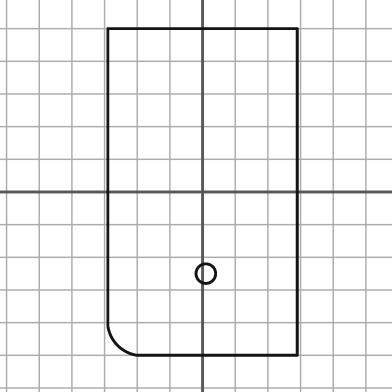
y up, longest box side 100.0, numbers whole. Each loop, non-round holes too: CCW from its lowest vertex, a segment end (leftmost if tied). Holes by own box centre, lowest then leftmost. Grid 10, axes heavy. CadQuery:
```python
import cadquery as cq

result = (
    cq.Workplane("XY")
    .moveTo(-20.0, -50.0)
    .lineTo(29.0, -50.0)
    .lineTo(29.0, 50.0)
    .lineTo(-29.0, 50.0)
    .lineTo(-29.0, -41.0)
    .threePointArc((-26.0, -47.0), (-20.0, -50.0))
    .close()
    .moveTo(1.0, -25.0)
    .circle(3.0)
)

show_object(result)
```